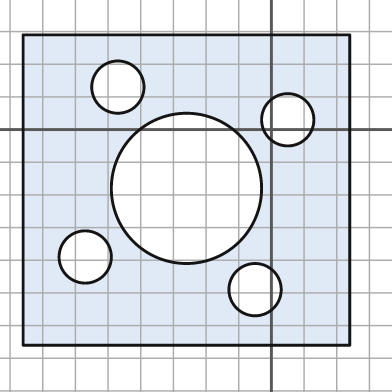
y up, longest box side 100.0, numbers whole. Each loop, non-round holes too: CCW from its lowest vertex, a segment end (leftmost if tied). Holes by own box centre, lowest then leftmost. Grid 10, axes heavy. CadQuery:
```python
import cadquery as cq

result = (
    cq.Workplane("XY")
    .moveTo(-76.0, -66.0)
    .lineTo(24.0, -66.0)
    .lineTo(24.0, 29.0)
    .lineTo(-76.0, 29.0)
    .close()
    .moveTo(-5.0, -49.0)
    .circle(8.0)
    .moveTo(-57.0, -39.0)
    .circle(8.0)
    .moveTo(-26.0, -18.0)
    .circle(23.0)
    .moveTo(5.0, 3.0)
    .circle(8.0)
    .moveTo(-47.0, 13.0)
    .circle(8.0)
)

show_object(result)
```